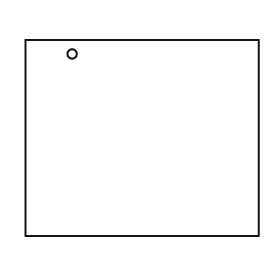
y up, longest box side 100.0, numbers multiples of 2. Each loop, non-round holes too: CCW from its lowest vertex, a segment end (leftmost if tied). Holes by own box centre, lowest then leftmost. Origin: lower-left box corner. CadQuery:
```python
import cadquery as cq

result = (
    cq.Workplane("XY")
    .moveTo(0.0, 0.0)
    .lineTo(100.0, 0.0)
    .lineTo(100.0, 84.0)
    .lineTo(0.0, 84.0)
    .close()
    .moveTo(20.0, 78.0)
    .circle(2.0)
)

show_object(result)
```